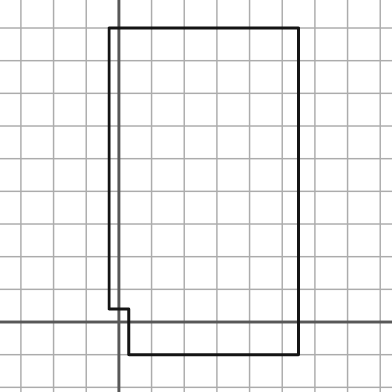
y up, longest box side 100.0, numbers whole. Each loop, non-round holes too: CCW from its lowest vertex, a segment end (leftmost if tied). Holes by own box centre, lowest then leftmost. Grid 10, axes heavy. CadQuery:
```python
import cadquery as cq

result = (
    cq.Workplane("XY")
    .moveTo(3.0, -10.0)
    .lineTo(55.0, -10.0)
    .lineTo(55.0, 90.0)
    .lineTo(-3.0, 90.0)
    .lineTo(-3.0, 4.0)
    .lineTo(3.0, 4.0)
    .close()
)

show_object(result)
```